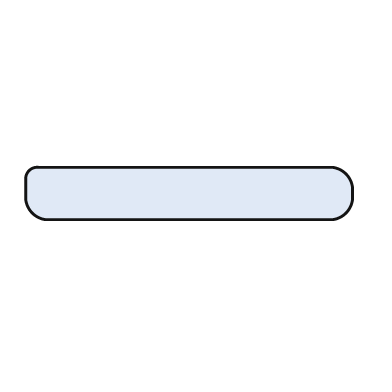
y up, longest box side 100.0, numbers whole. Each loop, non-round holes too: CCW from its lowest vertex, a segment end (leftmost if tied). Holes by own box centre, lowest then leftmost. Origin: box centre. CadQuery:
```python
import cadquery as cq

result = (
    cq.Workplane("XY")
    .moveTo(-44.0, -8.0)
    .lineTo(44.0, -8.0)
    .threePointArc((48.0, -6.0), (50.0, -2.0))
    .lineTo(50.0, 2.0)
    .threePointArc((48.0, 6.0), (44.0, 8.0))
    .lineTo(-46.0, 8.0)
    .threePointArc((-49.0, 7.0), (-50.0, 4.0))
    .lineTo(-50.0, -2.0)
    .threePointArc((-48.0, -6.0), (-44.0, -8.0))
    .close()
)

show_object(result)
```